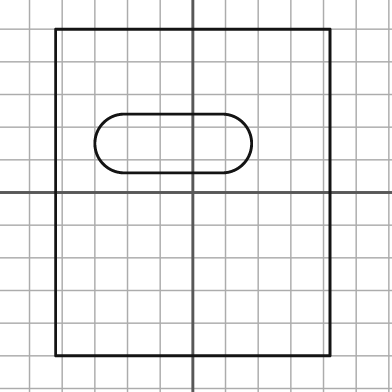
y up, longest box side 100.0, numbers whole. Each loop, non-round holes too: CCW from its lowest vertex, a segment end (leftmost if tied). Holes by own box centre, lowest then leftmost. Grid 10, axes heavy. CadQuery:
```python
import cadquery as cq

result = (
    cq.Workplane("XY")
    .moveTo(-42.0, -50.0)
    .lineTo(42.0, -50.0)
    .lineTo(42.0, 50.0)
    .lineTo(-42.0, 50.0)
    .close()
    .moveTo(-21.0, 6.0)
    .lineTo(9.0, 6.0)
    .threePointArc((18.0, 15.0), (9.0, 24.0))
    .lineTo(-21.0, 24.0)
    .threePointArc((-30.0, 15.0), (-21.0, 6.0))
    .close()
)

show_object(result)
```